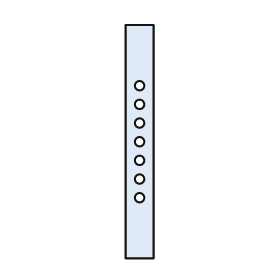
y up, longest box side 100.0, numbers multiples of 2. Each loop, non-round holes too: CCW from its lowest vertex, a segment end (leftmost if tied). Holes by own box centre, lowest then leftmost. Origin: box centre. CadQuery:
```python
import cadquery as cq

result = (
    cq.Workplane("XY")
    .moveTo(-6.0, -50.0)
    .lineTo(6.0, -50.0)
    .lineTo(6.0, 50.0)
    .lineTo(-6.0, 50.0)
    .close()
    .moveTo(0.0, -24.0)
    .circle(2.0)
    .moveTo(0.0, -16.0)
    .circle(2.0)
    .moveTo(0.0, -8.0)
    .circle(2.0)
    .moveTo(0.0, 0.0)
    .circle(2.0)
    .moveTo(0.0, 8.0)
    .circle(2.0)
    .moveTo(0.0, 16.0)
    .circle(2.0)
    .moveTo(0.0, 24.0)
    .circle(2.0)
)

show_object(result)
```